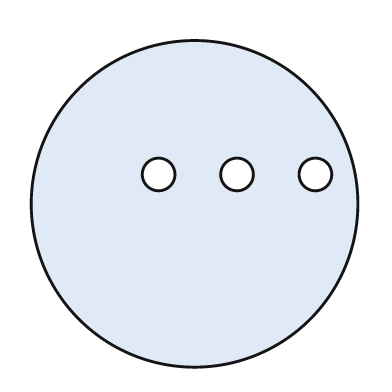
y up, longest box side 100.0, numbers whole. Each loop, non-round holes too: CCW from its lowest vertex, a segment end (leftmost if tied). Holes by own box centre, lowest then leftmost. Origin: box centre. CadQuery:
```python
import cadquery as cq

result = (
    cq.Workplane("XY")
    .moveTo(0.0, 0.0)
    .circle(50.0)
    .moveTo(-11.0, 9.0)
    .circle(5.0)
    .moveTo(13.0, 9.0)
    .circle(5.0)
    .moveTo(37.0, 9.0)
    .circle(5.0)
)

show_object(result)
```